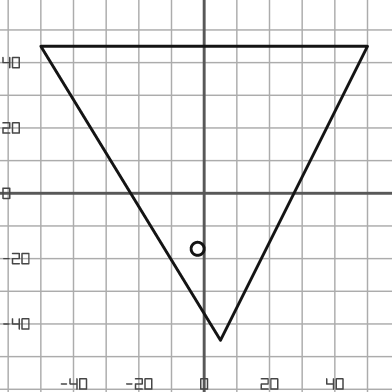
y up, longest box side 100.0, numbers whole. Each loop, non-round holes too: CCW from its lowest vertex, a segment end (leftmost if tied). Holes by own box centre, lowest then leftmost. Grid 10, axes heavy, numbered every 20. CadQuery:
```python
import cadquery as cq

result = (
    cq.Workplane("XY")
    .moveTo(5.0, -45.0)
    .lineTo(50.0, 45.0)
    .lineTo(-50.0, 45.0)
    .close()
    .moveTo(-2.0, -17.0)
    .circle(2.0)
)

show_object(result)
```